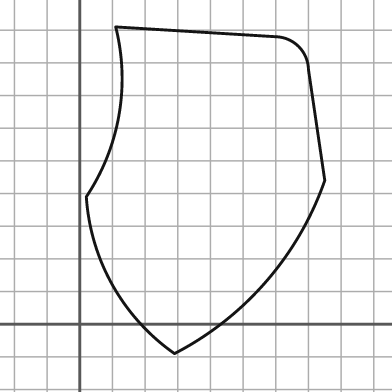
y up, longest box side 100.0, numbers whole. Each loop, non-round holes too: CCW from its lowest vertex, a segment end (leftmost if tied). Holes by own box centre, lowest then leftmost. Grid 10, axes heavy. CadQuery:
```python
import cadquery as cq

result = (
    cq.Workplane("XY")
    .moveTo(29.0, -9.0)
    .threePointArc((57.0, 13.0), (75.0, 44.0))
    .lineTo(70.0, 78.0)
    .threePointArc((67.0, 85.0), (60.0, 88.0))
    .lineTo(11.0, 91.0)
    .threePointArc((12.0, 64.0), (2.0, 39.0))
    .threePointArc((10.0, 12.0), (29.0, -9.0))
    .close()
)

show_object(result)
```